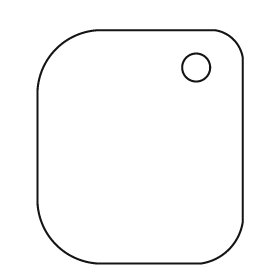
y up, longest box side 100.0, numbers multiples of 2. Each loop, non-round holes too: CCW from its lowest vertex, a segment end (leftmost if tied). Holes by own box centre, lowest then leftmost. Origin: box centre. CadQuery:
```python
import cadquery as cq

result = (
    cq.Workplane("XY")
    .moveTo(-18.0, -50.0)
    .lineTo(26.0, -50.0)
    .threePointArc((38.0, -44.0), (44.0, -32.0))
    .lineTo(44.0, 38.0)
    .threePointArc((40.0, 46.0), (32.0, 50.0))
    .lineTo(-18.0, 50.0)
    .threePointArc((-36.0, 42.0), (-44.0, 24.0))
    .lineTo(-44.0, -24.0)
    .threePointArc((-36.0, -42.0), (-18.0, -50.0))
    .close()
    .moveTo(24.0, 34.0)
    .circle(6.0)
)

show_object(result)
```